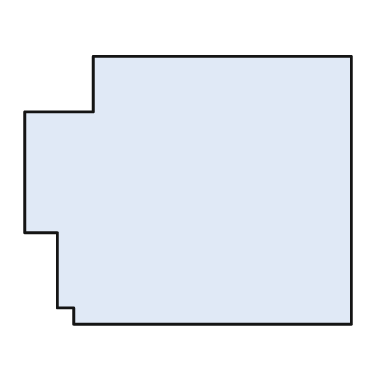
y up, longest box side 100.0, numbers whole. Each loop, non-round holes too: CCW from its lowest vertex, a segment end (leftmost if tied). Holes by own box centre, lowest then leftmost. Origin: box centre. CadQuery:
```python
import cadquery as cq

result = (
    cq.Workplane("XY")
    .moveTo(-35.0, -41.0)
    .lineTo(50.0, -41.0)
    .lineTo(50.0, 41.0)
    .lineTo(-29.0, 41.0)
    .lineTo(-29.0, 24.0)
    .lineTo(-50.0, 24.0)
    .lineTo(-50.0, -13.0)
    .lineTo(-40.0, -13.0)
    .lineTo(-40.0, -36.0)
    .lineTo(-35.0, -36.0)
    .close()
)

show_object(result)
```